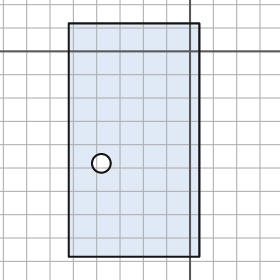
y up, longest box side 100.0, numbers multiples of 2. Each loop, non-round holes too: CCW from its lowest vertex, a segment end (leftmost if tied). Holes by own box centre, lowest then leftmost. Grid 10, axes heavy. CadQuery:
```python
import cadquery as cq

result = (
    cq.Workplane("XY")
    .moveTo(-52.0, -88.0)
    .lineTo(4.0, -88.0)
    .lineTo(4.0, 12.0)
    .lineTo(-52.0, 12.0)
    .close()
    .moveTo(-38.0, -48.0)
    .circle(4.0)
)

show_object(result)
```